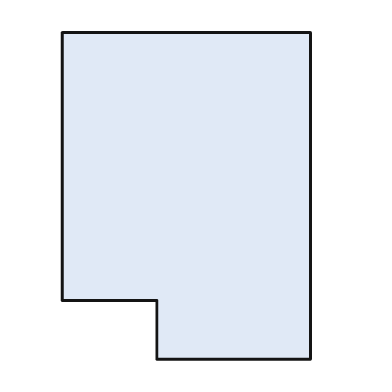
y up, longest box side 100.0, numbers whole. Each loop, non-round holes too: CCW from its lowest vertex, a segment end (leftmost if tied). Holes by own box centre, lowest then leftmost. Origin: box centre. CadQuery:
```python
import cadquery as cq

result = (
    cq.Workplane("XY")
    .moveTo(-9.0, -50.0)
    .lineTo(38.0, -50.0)
    .lineTo(38.0, 50.0)
    .lineTo(-38.0, 50.0)
    .lineTo(-38.0, -32.0)
    .lineTo(-9.0, -32.0)
    .close()
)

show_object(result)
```